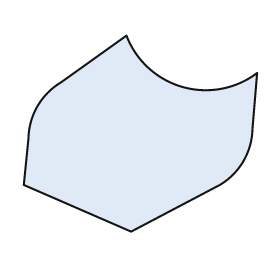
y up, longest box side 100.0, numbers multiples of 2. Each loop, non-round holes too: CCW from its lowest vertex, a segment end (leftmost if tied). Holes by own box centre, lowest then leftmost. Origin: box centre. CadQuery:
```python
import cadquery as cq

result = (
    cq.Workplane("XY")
    .moveTo(-4.0, -42.0)
    .lineTo(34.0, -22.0)
    .threePointArc((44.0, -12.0), (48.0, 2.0))
    .lineTo(50.0, 26.0)
    .threePointArc((18.0, 20.0), (-6.0, 42.0))
    .lineTo(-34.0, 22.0)
    .threePointArc((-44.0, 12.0), (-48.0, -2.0))
    .lineTo(-50.0, -22.0)
    .close()
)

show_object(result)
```